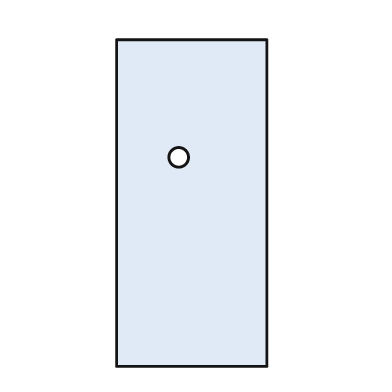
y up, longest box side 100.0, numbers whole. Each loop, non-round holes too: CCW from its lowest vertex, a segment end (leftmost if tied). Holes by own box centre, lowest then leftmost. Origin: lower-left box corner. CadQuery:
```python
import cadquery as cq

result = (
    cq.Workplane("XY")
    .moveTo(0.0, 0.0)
    .lineTo(46.0, 0.0)
    .lineTo(46.0, 100.0)
    .lineTo(0.0, 100.0)
    .close()
    .moveTo(19.0, 64.0)
    .circle(3.0)
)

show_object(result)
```